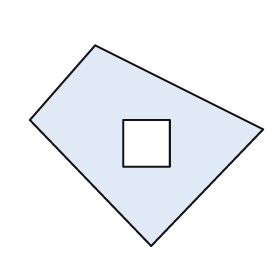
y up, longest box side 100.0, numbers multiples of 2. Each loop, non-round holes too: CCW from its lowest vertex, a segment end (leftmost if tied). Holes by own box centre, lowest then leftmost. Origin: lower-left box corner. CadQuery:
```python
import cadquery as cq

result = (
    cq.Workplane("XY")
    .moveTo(52.0, 0.0)
    .lineTo(100.0, 50.0)
    .lineTo(28.0, 86.0)
    .lineTo(0.0, 54.0)
    .close()
    .moveTo(40.0, 34.0)
    .lineTo(60.0, 34.0)
    .lineTo(60.0, 54.0)
    .lineTo(40.0, 54.0)
    .close()
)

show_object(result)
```